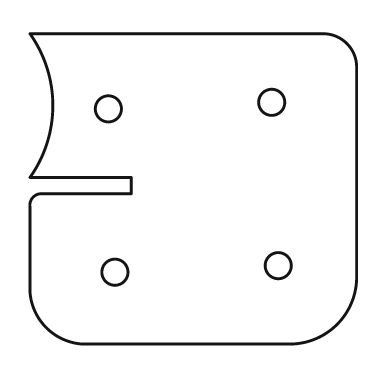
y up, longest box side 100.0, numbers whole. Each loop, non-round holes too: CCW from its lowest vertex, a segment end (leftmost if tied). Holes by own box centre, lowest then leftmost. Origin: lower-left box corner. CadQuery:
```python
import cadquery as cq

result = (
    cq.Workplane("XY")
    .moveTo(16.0, 0.0)
    .lineTo(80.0, 0.0)
    .threePointArc((94.0, 6.0), (100.0, 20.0))
    .lineTo(100.0, 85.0)
    .threePointArc((97.0, 92.0), (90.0, 95.0))
    .lineTo(0.0, 95.0)
    .threePointArc((7.0, 73.0), (0.0, 51.0))
    .lineTo(31.0, 51.0)
    .lineTo(31.0, 46.0)
    .lineTo(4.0, 46.0)
    .threePointArc((1.0, 45.0), (0.0, 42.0))
    .lineTo(0.0, 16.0)
    .threePointArc((5.0, 5.0), (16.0, 0.0))
    .close()
    .moveTo(26.0, 22.0)
    .circle(4.0)
    .moveTo(76.0, 24.0)
    .circle(4.0)
    .moveTo(24.0, 72.0)
    .circle(4.0)
    .moveTo(74.0, 74.0)
    .circle(4.0)
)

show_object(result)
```